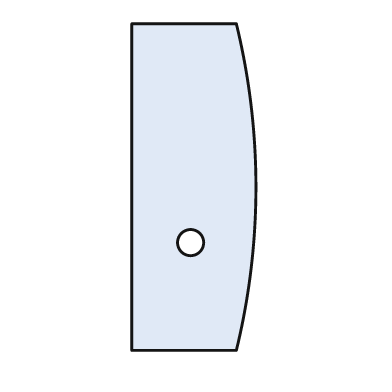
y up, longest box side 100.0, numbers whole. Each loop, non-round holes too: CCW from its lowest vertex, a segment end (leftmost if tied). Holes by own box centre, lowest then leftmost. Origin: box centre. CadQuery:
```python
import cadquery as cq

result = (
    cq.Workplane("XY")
    .moveTo(-19.0, -50.0)
    .lineTo(13.0, -50.0)
    .threePointArc((19.0, 0.0), (13.0, 50.0))
    .lineTo(-19.0, 50.0)
    .close()
    .moveTo(-1.0, -17.0)
    .circle(4.0)
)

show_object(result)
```